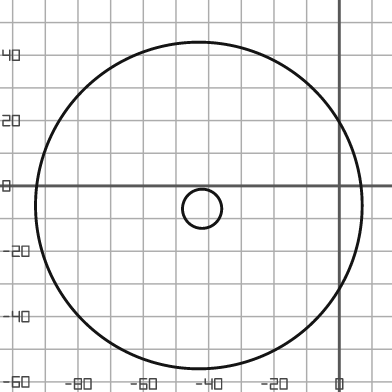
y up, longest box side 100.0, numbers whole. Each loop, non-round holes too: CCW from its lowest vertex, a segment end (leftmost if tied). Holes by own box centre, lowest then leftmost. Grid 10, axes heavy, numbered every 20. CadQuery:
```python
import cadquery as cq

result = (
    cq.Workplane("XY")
    .moveTo(-43.0, -6.0)
    .circle(50.0)
    .moveTo(-42.0, -7.0)
    .circle(6.0)
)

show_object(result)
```